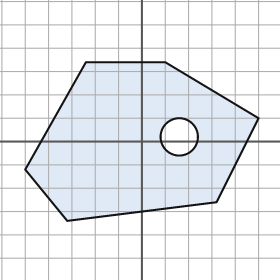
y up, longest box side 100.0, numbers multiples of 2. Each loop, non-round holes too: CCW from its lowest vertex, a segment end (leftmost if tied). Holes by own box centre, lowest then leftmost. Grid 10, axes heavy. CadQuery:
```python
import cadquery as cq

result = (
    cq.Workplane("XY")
    .moveTo(-32.0, -34.0)
    .lineTo(32.0, -26.0)
    .lineTo(50.0, 10.0)
    .lineTo(10.0, 34.0)
    .lineTo(-24.0, 34.0)
    .lineTo(-50.0, -12.0)
    .close()
    .moveTo(16.0, 2.0)
    .circle(8.0)
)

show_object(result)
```